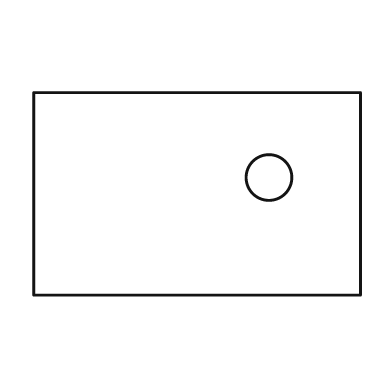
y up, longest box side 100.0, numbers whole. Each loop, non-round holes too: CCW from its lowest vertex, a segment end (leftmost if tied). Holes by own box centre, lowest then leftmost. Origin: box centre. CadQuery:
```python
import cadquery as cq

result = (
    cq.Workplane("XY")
    .moveTo(-50.0, -31.0)
    .lineTo(50.0, -31.0)
    .lineTo(50.0, 31.0)
    .lineTo(-50.0, 31.0)
    .close()
    .moveTo(22.0, 5.0)
    .circle(7.0)
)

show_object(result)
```